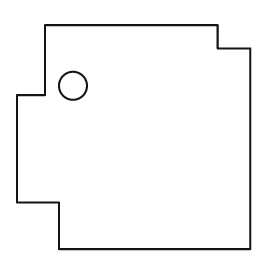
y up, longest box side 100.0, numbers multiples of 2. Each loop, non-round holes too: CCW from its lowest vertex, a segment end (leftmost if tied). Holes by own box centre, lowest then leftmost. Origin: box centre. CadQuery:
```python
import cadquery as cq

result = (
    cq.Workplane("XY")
    .moveTo(-32.0, -48.0)
    .lineTo(50.0, -48.0)
    .lineTo(50.0, 38.0)
    .lineTo(36.0, 38.0)
    .lineTo(36.0, 48.0)
    .lineTo(-38.0, 48.0)
    .lineTo(-38.0, 18.0)
    .lineTo(-50.0, 18.0)
    .lineTo(-50.0, -28.0)
    .lineTo(-32.0, -28.0)
    .close()
    .moveTo(-26.0, 22.0)
    .circle(6.0)
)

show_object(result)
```